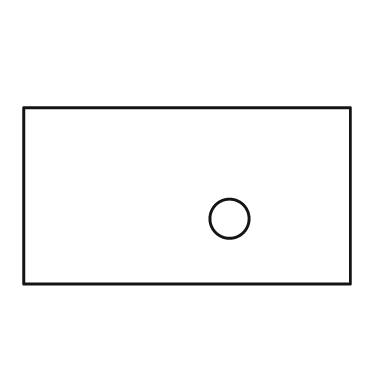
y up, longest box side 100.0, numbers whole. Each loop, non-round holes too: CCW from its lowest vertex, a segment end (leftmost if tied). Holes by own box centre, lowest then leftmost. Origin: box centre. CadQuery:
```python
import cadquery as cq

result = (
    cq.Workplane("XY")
    .moveTo(-50.0, -27.0)
    .lineTo(50.0, -27.0)
    .lineTo(50.0, 27.0)
    .lineTo(-50.0, 27.0)
    .close()
    .moveTo(13.0, -7.0)
    .circle(6.0)
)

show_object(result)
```